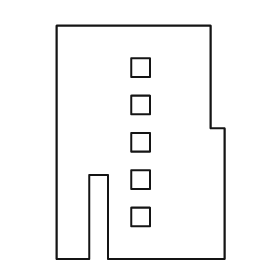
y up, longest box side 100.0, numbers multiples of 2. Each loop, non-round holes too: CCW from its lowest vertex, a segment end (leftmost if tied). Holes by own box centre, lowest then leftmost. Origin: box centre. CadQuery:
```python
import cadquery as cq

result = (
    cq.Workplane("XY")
    .moveTo(-36.0, -50.0)
    .lineTo(-22.0, -50.0)
    .lineTo(-22.0, -14.0)
    .lineTo(-14.0, -14.0)
    .lineTo(-14.0, -50.0)
    .lineTo(36.0, -50.0)
    .lineTo(36.0, 6.0)
    .lineTo(30.0, 6.0)
    .lineTo(30.0, 50.0)
    .lineTo(-36.0, 50.0)
    .close()
    .moveTo(-4.0, -36.0)
    .lineTo(4.0, -36.0)
    .lineTo(4.0, -28.0)
    .lineTo(-4.0, -28.0)
    .close()
    .moveTo(-4.0, -20.0)
    .lineTo(4.0, -20.0)
    .lineTo(4.0, -12.0)
    .lineTo(-4.0, -12.0)
    .close()
    .moveTo(-4.0, -4.0)
    .lineTo(4.0, -4.0)
    .lineTo(4.0, 4.0)
    .lineTo(-4.0, 4.0)
    .close()
    .moveTo(-4.0, 12.0)
    .lineTo(4.0, 12.0)
    .lineTo(4.0, 20.0)
    .lineTo(-4.0, 20.0)
    .close()
    .moveTo(-4.0, 28.0)
    .lineTo(4.0, 28.0)
    .lineTo(4.0, 36.0)
    .lineTo(-4.0, 36.0)
    .close()
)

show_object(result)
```